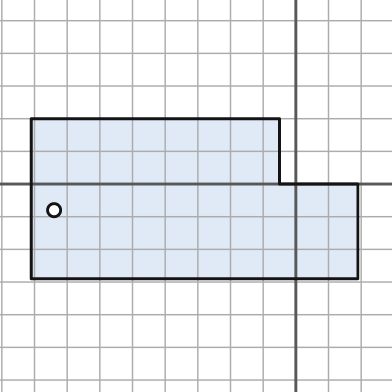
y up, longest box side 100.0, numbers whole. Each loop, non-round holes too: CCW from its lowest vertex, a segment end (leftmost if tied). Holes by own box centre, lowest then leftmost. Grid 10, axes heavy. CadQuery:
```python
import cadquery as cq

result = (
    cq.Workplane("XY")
    .moveTo(-81.0, -29.0)
    .lineTo(19.0, -29.0)
    .lineTo(19.0, 0.0)
    .lineTo(-5.0, 0.0)
    .lineTo(-5.0, 20.0)
    .lineTo(-81.0, 20.0)
    .close()
    .moveTo(-74.0, -8.0)
    .circle(2.0)
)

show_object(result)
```